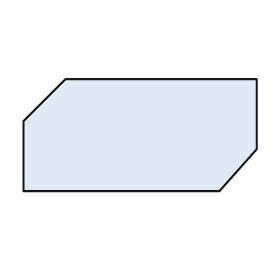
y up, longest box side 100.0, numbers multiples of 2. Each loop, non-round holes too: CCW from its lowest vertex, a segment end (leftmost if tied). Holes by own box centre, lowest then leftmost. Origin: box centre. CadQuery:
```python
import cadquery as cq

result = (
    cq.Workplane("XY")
    .moveTo(-50.0, -24.0)
    .lineTo(34.0, -24.0)
    .lineTo(50.0, -6.0)
    .lineTo(50.0, 24.0)
    .lineTo(-32.0, 24.0)
    .lineTo(-50.0, 6.0)
    .close()
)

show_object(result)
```